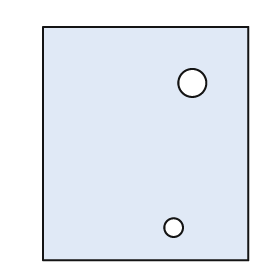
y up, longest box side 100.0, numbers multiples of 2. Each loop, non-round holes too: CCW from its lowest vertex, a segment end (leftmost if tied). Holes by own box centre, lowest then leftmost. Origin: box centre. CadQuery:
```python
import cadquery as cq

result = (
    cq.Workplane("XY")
    .moveTo(-44.0, -50.0)
    .lineTo(44.0, -50.0)
    .lineTo(44.0, 50.0)
    .lineTo(-44.0, 50.0)
    .close()
    .moveTo(12.0, -36.0)
    .circle(4.0)
    .moveTo(20.0, 26.0)
    .circle(6.0)
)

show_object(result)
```